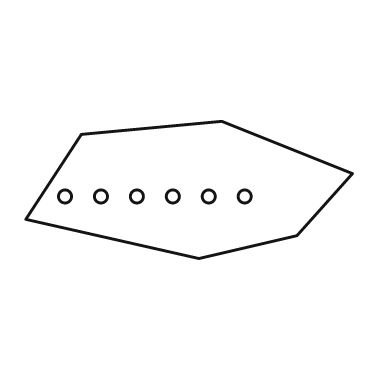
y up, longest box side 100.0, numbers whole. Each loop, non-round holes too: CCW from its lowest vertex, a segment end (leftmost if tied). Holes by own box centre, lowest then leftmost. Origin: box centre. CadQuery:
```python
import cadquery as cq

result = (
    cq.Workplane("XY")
    .moveTo(3.0, -21.0)
    .lineTo(33.0, -14.0)
    .lineTo(50.0, 5.0)
    .lineTo(10.0, 21.0)
    .lineTo(-33.0, 17.0)
    .lineTo(-50.0, -9.0)
    .close()
    .moveTo(-38.0, -2.0)
    .circle(2.0)
    .moveTo(-27.0, -2.0)
    .circle(2.0)
    .moveTo(-16.0, -2.0)
    .circle(2.0)
    .moveTo(-5.0, -2.0)
    .circle(2.0)
    .moveTo(6.0, -2.0)
    .circle(2.0)
    .moveTo(17.0, -2.0)
    .circle(2.0)
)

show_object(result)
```